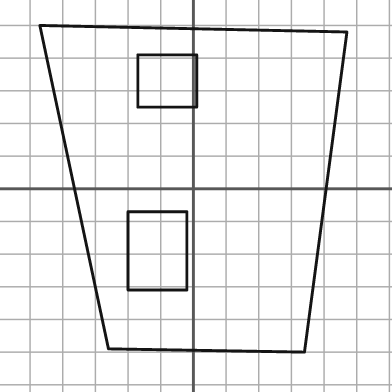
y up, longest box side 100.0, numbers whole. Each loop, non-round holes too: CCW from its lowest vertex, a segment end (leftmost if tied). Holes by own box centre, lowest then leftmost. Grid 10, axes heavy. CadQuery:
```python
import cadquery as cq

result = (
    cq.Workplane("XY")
    .moveTo(34.0, -50.0)
    .lineTo(47.0, 48.0)
    .lineTo(-47.0, 50.0)
    .lineTo(-26.0, -49.0)
    .close()
    .moveTo(-20.0, -31.0)
    .lineTo(-2.0, -31.0)
    .lineTo(-2.0, -7.0)
    .lineTo(-20.0, -7.0)
    .close()
    .moveTo(-17.0, 25.0)
    .lineTo(1.0, 25.0)
    .lineTo(1.0, 41.0)
    .lineTo(-17.0, 41.0)
    .close()
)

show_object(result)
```